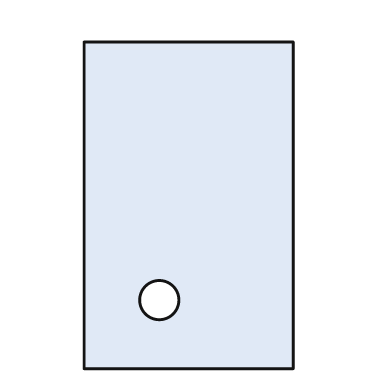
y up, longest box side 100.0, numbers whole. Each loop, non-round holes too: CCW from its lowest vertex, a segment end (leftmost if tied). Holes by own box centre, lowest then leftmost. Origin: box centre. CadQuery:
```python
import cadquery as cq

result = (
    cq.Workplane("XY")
    .moveTo(-32.0, -50.0)
    .lineTo(32.0, -50.0)
    .lineTo(32.0, 50.0)
    .lineTo(-32.0, 50.0)
    .close()
    .moveTo(-9.0, -29.0)
    .circle(6.0)
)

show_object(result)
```